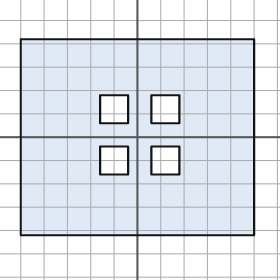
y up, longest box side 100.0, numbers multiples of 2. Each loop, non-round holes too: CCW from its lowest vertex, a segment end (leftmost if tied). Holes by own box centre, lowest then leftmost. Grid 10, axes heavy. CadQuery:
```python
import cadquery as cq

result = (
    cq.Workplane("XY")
    .moveTo(-50.0, -42.0)
    .lineTo(50.0, -42.0)
    .lineTo(50.0, 42.0)
    .lineTo(-50.0, 42.0)
    .close()
    .moveTo(-16.0, -16.0)
    .lineTo(-4.0, -16.0)
    .lineTo(-4.0, -4.0)
    .lineTo(-16.0, -4.0)
    .close()
    .moveTo(6.0, -16.0)
    .lineTo(18.0, -16.0)
    .lineTo(18.0, -4.0)
    .lineTo(6.0, -4.0)
    .close()
    .moveTo(-16.0, 6.0)
    .lineTo(-4.0, 6.0)
    .lineTo(-4.0, 18.0)
    .lineTo(-16.0, 18.0)
    .close()
    .moveTo(6.0, 6.0)
    .lineTo(18.0, 6.0)
    .lineTo(18.0, 18.0)
    .lineTo(6.0, 18.0)
    .close()
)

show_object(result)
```